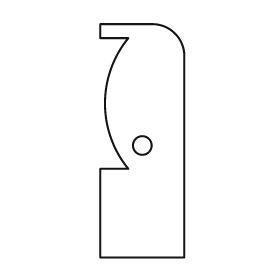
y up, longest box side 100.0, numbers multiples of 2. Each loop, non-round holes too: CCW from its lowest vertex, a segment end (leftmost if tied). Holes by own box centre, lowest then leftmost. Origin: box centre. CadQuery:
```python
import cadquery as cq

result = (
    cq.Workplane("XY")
    .moveTo(-18.0, -50.0)
    .lineTo(18.0, -50.0)
    .lineTo(18.0, 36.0)
    .threePointArc((14.0, 46.0), (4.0, 50.0))
    .lineTo(-18.0, 50.0)
    .lineTo(-18.0, 44.0)
    .lineTo(-6.0, 44.0)
    .threePointArc((-16.0, 16.0), (-6.0, -12.0))
    .lineTo(-18.0, -12.0)
    .close()
    .moveTo(0.0, -2.0)
    .circle(4.0)
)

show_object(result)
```